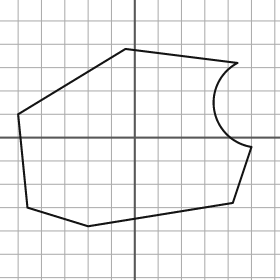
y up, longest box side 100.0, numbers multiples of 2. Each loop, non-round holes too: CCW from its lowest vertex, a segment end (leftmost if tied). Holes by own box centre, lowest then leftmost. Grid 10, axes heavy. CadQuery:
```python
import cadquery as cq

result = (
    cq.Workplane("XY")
    .moveTo(-20.0, -38.0)
    .lineTo(42.0, -28.0)
    .lineTo(50.0, -4.0)
    .threePointArc((34.0, 12.0), (44.0, 32.0))
    .lineTo(-4.0, 38.0)
    .lineTo(-50.0, 10.0)
    .lineTo(-46.0, -30.0)
    .close()
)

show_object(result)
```